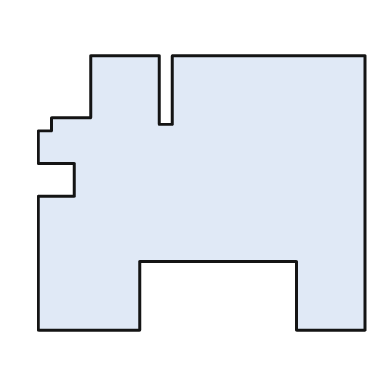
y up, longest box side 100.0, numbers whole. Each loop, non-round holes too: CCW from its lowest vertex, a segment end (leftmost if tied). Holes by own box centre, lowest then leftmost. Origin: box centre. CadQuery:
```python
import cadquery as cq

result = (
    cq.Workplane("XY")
    .moveTo(-50.0, -42.0)
    .lineTo(-19.0, -42.0)
    .lineTo(-19.0, -21.0)
    .lineTo(29.0, -21.0)
    .lineTo(29.0, -42.0)
    .lineTo(50.0, -42.0)
    .lineTo(50.0, 42.0)
    .lineTo(-9.0, 42.0)
    .lineTo(-9.0, 21.0)
    .lineTo(-13.0, 21.0)
    .lineTo(-13.0, 42.0)
    .lineTo(-34.0, 42.0)
    .lineTo(-34.0, 23.0)
    .lineTo(-46.0, 23.0)
    .lineTo(-46.0, 19.0)
    .lineTo(-50.0, 19.0)
    .lineTo(-50.0, 9.0)
    .lineTo(-39.0, 9.0)
    .lineTo(-39.0, -1.0)
    .lineTo(-50.0, -1.0)
    .close()
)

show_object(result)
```